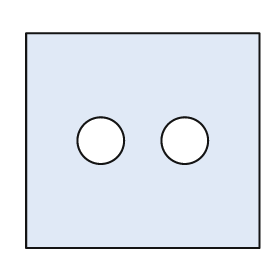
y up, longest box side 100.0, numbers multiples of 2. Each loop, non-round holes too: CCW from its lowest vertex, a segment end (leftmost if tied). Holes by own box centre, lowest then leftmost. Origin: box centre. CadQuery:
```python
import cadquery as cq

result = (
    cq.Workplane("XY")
    .moveTo(-50.0, -46.0)
    .lineTo(50.0, -46.0)
    .lineTo(50.0, 46.0)
    .lineTo(-50.0, 46.0)
    .close()
    .moveTo(-18.0, 0.0)
    .circle(10.0)
    .moveTo(18.0, 0.0)
    .circle(10.0)
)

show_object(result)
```